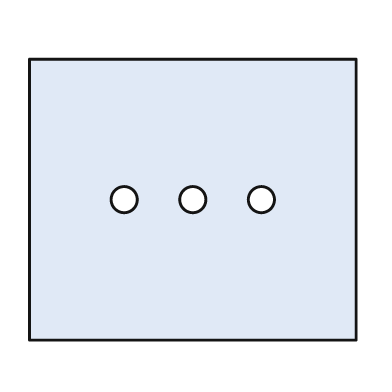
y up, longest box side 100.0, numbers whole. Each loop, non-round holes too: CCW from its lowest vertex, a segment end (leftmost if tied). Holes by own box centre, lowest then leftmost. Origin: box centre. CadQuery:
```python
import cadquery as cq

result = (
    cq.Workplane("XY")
    .moveTo(-50.0, -43.0)
    .lineTo(50.0, -43.0)
    .lineTo(50.0, 43.0)
    .lineTo(-50.0, 43.0)
    .close()
    .moveTo(-21.0, 0.0)
    .circle(4.0)
    .moveTo(0.0, 0.0)
    .circle(4.0)
    .moveTo(21.0, 0.0)
    .circle(4.0)
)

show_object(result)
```